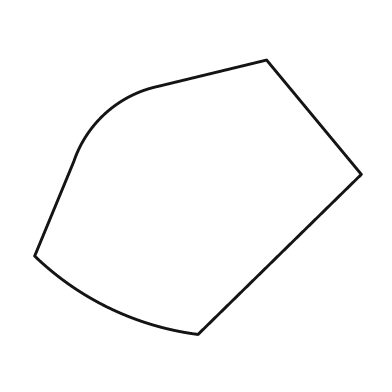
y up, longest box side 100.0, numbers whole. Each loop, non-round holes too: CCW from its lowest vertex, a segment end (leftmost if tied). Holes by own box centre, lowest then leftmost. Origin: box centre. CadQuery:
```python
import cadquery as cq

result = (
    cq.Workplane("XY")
    .moveTo(0.0, -42.0)
    .lineTo(50.0, 7.0)
    .lineTo(21.0, 42.0)
    .lineTo(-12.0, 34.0)
    .threePointArc((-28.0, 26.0), (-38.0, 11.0))
    .lineTo(-50.0, -18.0)
    .threePointArc((-27.0, -34.0), (0.0, -42.0))
    .close()
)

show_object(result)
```